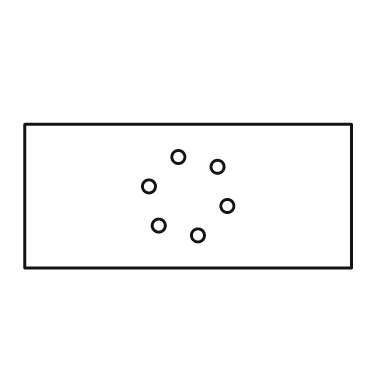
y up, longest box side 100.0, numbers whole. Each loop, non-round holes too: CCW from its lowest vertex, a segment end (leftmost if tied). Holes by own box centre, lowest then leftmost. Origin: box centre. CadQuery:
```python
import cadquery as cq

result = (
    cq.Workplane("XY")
    .moveTo(-50.0, -22.0)
    .lineTo(50.0, -22.0)
    .lineTo(50.0, 22.0)
    .lineTo(-50.0, 22.0)
    .close()
    .moveTo(3.0, -12.0)
    .circle(2.0)
    .moveTo(-9.0, -9.0)
    .circle(2.0)
    .moveTo(12.0, -3.0)
    .circle(2.0)
    .moveTo(-12.0, 3.0)
    .circle(2.0)
    .moveTo(9.0, 9.0)
    .circle(2.0)
    .moveTo(-3.0, 12.0)
    .circle(2.0)
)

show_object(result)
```